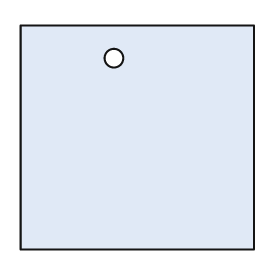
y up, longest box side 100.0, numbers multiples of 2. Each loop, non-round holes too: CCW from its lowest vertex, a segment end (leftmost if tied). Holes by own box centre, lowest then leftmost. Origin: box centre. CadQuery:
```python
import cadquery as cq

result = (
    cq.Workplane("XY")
    .moveTo(-50.0, -48.0)
    .lineTo(50.0, -48.0)
    .lineTo(50.0, 48.0)
    .lineTo(-50.0, 48.0)
    .close()
    .moveTo(-10.0, 34.0)
    .circle(4.0)
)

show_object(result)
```